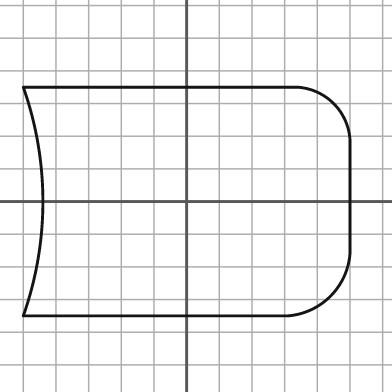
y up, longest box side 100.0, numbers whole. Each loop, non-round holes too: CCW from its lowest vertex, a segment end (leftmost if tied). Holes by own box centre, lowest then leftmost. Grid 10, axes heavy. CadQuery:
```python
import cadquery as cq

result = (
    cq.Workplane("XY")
    .moveTo(-50.0, -35.0)
    .lineTo(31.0, -35.0)
    .threePointArc((44.0, -29.0), (50.0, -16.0))
    .lineTo(50.0, 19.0)
    .threePointArc((45.0, 30.0), (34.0, 35.0))
    .lineTo(-50.0, 35.0)
    .threePointArc((-44.0, 0.0), (-50.0, -35.0))
    .close()
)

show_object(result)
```